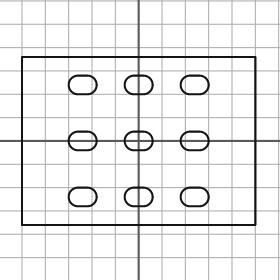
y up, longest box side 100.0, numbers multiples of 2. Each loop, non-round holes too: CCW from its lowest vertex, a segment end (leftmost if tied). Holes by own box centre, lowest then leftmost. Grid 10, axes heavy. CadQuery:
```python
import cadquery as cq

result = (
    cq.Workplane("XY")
    .moveTo(-50.0, -36.0)
    .lineTo(50.0, -36.0)
    .lineTo(50.0, 36.0)
    .lineTo(-50.0, 36.0)
    .close()
    .moveTo(-26.0, -28.0)
    .lineTo(-22.0, -28.0)
    .threePointArc((-18.0, -24.0), (-22.0, -20.0))
    .lineTo(-26.0, -20.0)
    .threePointArc((-30.0, -24.0), (-26.0, -28.0))
    .close()
    .moveTo(-2.0, -28.0)
    .lineTo(2.0, -28.0)
    .threePointArc((6.0, -24.0), (2.0, -20.0))
    .lineTo(-2.0, -20.0)
    .threePointArc((-6.0, -24.0), (-2.0, -28.0))
    .close()
    .moveTo(22.0, -28.0)
    .lineTo(26.0, -28.0)
    .threePointArc((30.0, -24.0), (26.0, -20.0))
    .lineTo(22.0, -20.0)
    .threePointArc((18.0, -24.0), (22.0, -28.0))
    .close()
    .moveTo(-26.0, -4.0)
    .lineTo(-22.0, -4.0)
    .threePointArc((-18.0, 0.0), (-22.0, 4.0))
    .lineTo(-26.0, 4.0)
    .threePointArc((-30.0, 0.0), (-26.0, -4.0))
    .close()
    .moveTo(-2.0, -4.0)
    .lineTo(2.0, -4.0)
    .threePointArc((6.0, 0.0), (2.0, 4.0))
    .lineTo(-2.0, 4.0)
    .threePointArc((-6.0, 0.0), (-2.0, -4.0))
    .close()
    .moveTo(22.0, -4.0)
    .lineTo(26.0, -4.0)
    .threePointArc((30.0, 0.0), (26.0, 4.0))
    .lineTo(22.0, 4.0)
    .threePointArc((18.0, 0.0), (22.0, -4.0))
    .close()
    .moveTo(-26.0, 20.0)
    .lineTo(-22.0, 20.0)
    .threePointArc((-18.0, 24.0), (-22.0, 28.0))
    .lineTo(-26.0, 28.0)
    .threePointArc((-30.0, 24.0), (-26.0, 20.0))
    .close()
    .moveTo(-2.0, 20.0)
    .lineTo(2.0, 20.0)
    .threePointArc((6.0, 24.0), (2.0, 28.0))
    .lineTo(-2.0, 28.0)
    .threePointArc((-6.0, 24.0), (-2.0, 20.0))
    .close()
    .moveTo(22.0, 20.0)
    .lineTo(26.0, 20.0)
    .threePointArc((30.0, 24.0), (26.0, 28.0))
    .lineTo(22.0, 28.0)
    .threePointArc((18.0, 24.0), (22.0, 20.0))
    .close()
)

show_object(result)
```